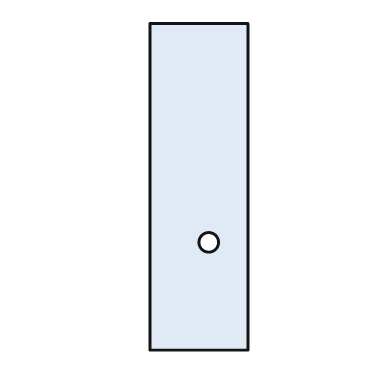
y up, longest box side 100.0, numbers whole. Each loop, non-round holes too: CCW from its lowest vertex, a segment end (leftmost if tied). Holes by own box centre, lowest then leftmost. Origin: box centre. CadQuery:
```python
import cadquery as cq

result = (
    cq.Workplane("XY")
    .moveTo(-15.0, -50.0)
    .lineTo(15.0, -50.0)
    .lineTo(15.0, 50.0)
    .lineTo(-15.0, 50.0)
    .close()
    .moveTo(3.0, -17.0)
    .circle(3.0)
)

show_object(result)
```